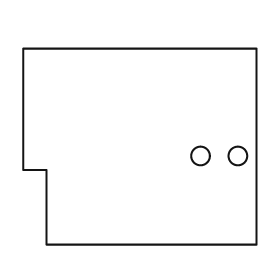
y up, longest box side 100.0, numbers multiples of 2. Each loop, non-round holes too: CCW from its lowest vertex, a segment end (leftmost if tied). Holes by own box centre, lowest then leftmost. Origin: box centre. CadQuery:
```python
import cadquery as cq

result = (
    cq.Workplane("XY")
    .moveTo(-40.0, -42.0)
    .lineTo(50.0, -42.0)
    .lineTo(50.0, 42.0)
    .lineTo(-50.0, 42.0)
    .lineTo(-50.0, -10.0)
    .lineTo(-40.0, -10.0)
    .close()
    .moveTo(26.0, -4.0)
    .circle(4.0)
    .moveTo(42.0, -4.0)
    .circle(4.0)
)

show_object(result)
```